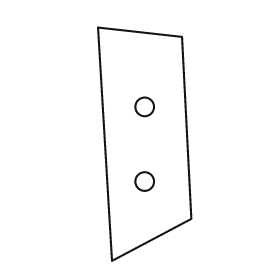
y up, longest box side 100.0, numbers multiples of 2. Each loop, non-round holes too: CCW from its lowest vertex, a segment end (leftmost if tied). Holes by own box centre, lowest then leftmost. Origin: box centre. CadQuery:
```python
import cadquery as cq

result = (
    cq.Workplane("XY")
    .moveTo(-14.0, -50.0)
    .lineTo(20.0, -32.0)
    .lineTo(16.0, 46.0)
    .lineTo(-20.0, 50.0)
    .close()
    .moveTo(0.0, -16.0)
    .circle(4.0)
    .moveTo(0.0, 16.0)
    .circle(4.0)
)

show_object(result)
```